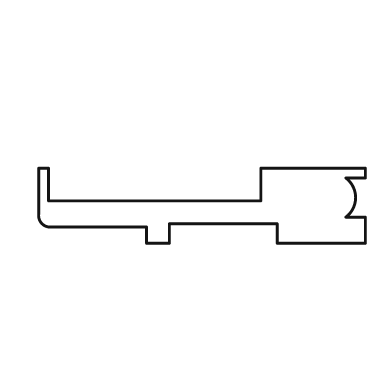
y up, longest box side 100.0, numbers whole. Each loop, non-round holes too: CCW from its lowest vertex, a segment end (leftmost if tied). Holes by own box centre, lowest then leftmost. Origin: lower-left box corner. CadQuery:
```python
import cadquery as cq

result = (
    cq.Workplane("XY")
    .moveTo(33.0, 0.0)
    .lineTo(40.0, 0.0)
    .lineTo(40.0, 6.0)
    .lineTo(73.0, 6.0)
    .lineTo(73.0, 0.0)
    .lineTo(100.0, 0.0)
    .lineTo(100.0, 8.0)
    .lineTo(94.0, 8.0)
    .threePointArc((97.0, 14.0), (94.0, 20.0))
    .lineTo(100.0, 20.0)
    .lineTo(100.0, 23.0)
    .lineTo(68.0, 23.0)
    .lineTo(68.0, 13.0)
    .lineTo(3.0, 13.0)
    .lineTo(3.0, 23.0)
    .lineTo(0.0, 23.0)
    .lineTo(0.0, 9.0)
    .threePointArc((1.0, 6.0), (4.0, 5.0))
    .lineTo(33.0, 5.0)
    .close()
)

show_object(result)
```